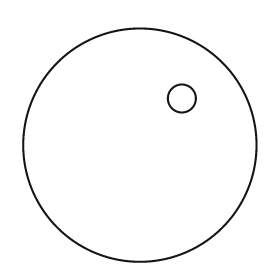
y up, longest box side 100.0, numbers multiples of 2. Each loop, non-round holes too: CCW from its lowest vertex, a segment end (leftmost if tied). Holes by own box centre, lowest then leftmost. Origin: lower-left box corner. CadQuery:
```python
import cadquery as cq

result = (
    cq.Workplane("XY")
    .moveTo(50.0, 50.0)
    .circle(50.0)
    .moveTo(68.0, 70.0)
    .circle(6.0)
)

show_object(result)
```